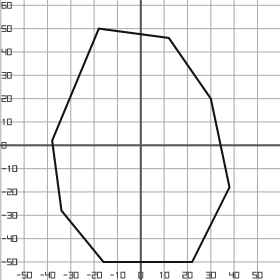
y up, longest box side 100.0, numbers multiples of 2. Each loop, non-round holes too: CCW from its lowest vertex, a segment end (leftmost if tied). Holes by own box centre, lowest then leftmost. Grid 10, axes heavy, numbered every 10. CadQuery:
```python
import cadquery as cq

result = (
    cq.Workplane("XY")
    .moveTo(-16.0, -50.0)
    .lineTo(22.0, -50.0)
    .lineTo(38.0, -18.0)
    .lineTo(30.0, 20.0)
    .lineTo(12.0, 46.0)
    .lineTo(-18.0, 50.0)
    .lineTo(-38.0, 2.0)
    .lineTo(-34.0, -28.0)
    .close()
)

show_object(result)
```